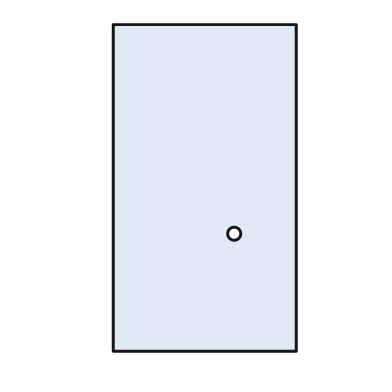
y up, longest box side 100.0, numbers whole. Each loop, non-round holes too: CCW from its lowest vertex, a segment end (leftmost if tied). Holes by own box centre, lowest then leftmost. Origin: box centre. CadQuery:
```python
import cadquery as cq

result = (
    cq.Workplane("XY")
    .moveTo(-28.0, -50.0)
    .lineTo(28.0, -50.0)
    .lineTo(28.0, 50.0)
    .lineTo(-28.0, 50.0)
    .close()
    .moveTo(9.0, -14.0)
    .circle(2.0)
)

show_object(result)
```